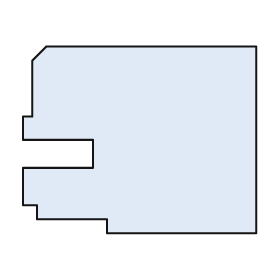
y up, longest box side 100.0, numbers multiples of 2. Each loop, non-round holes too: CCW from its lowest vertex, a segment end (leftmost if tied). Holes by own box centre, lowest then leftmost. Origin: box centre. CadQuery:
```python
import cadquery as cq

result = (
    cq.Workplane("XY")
    .moveTo(-14.0, -40.0)
    .lineTo(50.0, -40.0)
    .lineTo(50.0, 40.0)
    .lineTo(-40.0, 40.0)
    .lineTo(-46.0, 34.0)
    .lineTo(-46.0, 10.0)
    .lineTo(-50.0, 10.0)
    .lineTo(-50.0, 0.0)
    .lineTo(-20.0, 0.0)
    .lineTo(-20.0, -12.0)
    .lineTo(-50.0, -12.0)
    .lineTo(-50.0, -28.0)
    .lineTo(-44.0, -28.0)
    .lineTo(-44.0, -34.0)
    .lineTo(-14.0, -34.0)
    .close()
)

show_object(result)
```